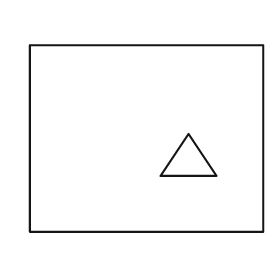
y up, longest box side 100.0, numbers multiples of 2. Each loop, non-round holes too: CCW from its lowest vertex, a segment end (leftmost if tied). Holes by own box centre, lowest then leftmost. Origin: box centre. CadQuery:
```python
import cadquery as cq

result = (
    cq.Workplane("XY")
    .moveTo(-50.0, -40.0)
    .lineTo(50.0, -40.0)
    .lineTo(50.0, 40.0)
    .lineTo(-50.0, 40.0)
    .close()
    .moveTo(6.0, -16.0)
    .lineTo(30.0, -16.0)
    .lineTo(18.0, 2.0)
    .close()
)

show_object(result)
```